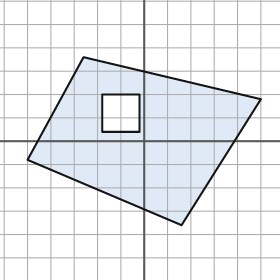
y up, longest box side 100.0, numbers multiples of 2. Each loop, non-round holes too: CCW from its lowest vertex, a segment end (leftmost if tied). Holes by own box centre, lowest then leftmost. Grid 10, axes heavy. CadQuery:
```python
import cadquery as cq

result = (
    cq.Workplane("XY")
    .moveTo(16.0, -36.0)
    .lineTo(50.0, 18.0)
    .lineTo(-26.0, 36.0)
    .lineTo(-50.0, -8.0)
    .close()
    .moveTo(-18.0, 4.0)
    .lineTo(-2.0, 4.0)
    .lineTo(-2.0, 20.0)
    .lineTo(-18.0, 20.0)
    .close()
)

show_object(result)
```